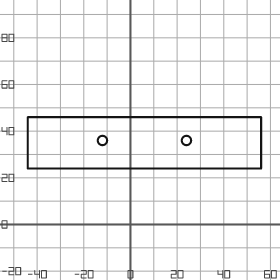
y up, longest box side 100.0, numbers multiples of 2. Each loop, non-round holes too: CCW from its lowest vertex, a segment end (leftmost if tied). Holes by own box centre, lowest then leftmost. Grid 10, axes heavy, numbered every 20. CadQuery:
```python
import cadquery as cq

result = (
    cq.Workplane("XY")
    .moveTo(-44.0, 24.0)
    .lineTo(56.0, 24.0)
    .lineTo(56.0, 46.0)
    .lineTo(-44.0, 46.0)
    .close()
    .moveTo(-12.0, 36.0)
    .circle(2.0)
    .moveTo(24.0, 36.0)
    .circle(2.0)
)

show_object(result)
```